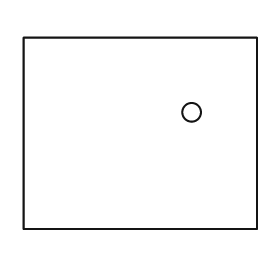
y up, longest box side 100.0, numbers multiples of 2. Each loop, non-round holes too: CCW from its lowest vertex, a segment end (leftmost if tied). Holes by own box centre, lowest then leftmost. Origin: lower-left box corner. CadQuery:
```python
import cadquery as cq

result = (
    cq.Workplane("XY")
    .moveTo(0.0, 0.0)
    .lineTo(100.0, 0.0)
    .lineTo(100.0, 82.0)
    .lineTo(0.0, 82.0)
    .close()
    .moveTo(72.0, 50.0)
    .circle(4.0)
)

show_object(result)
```